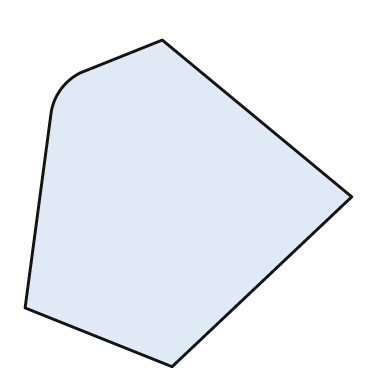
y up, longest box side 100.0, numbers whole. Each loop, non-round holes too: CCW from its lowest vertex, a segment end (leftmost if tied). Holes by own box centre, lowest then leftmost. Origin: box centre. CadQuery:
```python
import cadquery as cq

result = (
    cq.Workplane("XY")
    .moveTo(-5.0, -50.0)
    .lineTo(50.0, 2.0)
    .lineTo(-8.0, 50.0)
    .lineTo(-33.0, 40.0)
    .threePointArc((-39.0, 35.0), (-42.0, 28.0))
    .lineTo(-50.0, -32.0)
    .close()
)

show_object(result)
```